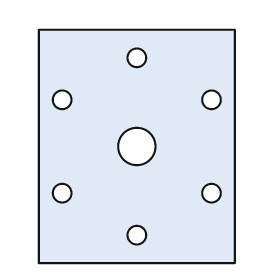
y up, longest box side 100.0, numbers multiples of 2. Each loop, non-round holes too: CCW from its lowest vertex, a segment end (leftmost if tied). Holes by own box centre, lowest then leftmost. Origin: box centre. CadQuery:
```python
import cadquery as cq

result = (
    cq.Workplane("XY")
    .moveTo(-42.0, -50.0)
    .lineTo(42.0, -50.0)
    .lineTo(42.0, 50.0)
    .lineTo(-42.0, 50.0)
    .close()
    .moveTo(0.0, -38.0)
    .circle(4.0)
    .moveTo(-32.0, -20.0)
    .circle(4.0)
    .moveTo(32.0, -20.0)
    .circle(4.0)
    .moveTo(0.0, 0.0)
    .circle(8.0)
    .moveTo(-32.0, 20.0)
    .circle(4.0)
    .moveTo(32.0, 20.0)
    .circle(4.0)
    .moveTo(0.0, 38.0)
    .circle(4.0)
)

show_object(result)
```